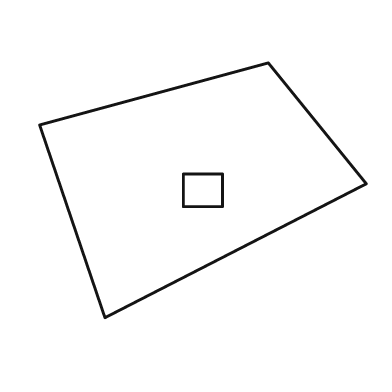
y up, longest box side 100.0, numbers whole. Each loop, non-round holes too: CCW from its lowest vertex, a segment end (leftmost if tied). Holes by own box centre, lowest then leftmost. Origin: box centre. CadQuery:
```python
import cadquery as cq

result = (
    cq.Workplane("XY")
    .moveTo(-30.0, -39.0)
    .lineTo(50.0, 2.0)
    .lineTo(20.0, 39.0)
    .lineTo(-50.0, 20.0)
    .close()
    .moveTo(-6.0, -5.0)
    .lineTo(6.0, -5.0)
    .lineTo(6.0, 5.0)
    .lineTo(-6.0, 5.0)
    .close()
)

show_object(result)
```